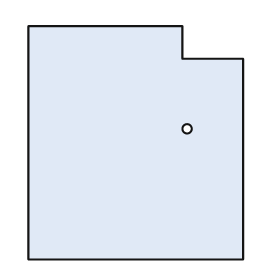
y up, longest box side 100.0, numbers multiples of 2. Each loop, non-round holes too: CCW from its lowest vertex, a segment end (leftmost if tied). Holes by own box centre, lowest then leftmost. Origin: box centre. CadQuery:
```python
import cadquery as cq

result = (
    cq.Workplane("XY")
    .moveTo(-46.0, -50.0)
    .lineTo(46.0, -50.0)
    .lineTo(46.0, 36.0)
    .lineTo(20.0, 36.0)
    .lineTo(20.0, 50.0)
    .lineTo(-46.0, 50.0)
    .close()
    .moveTo(22.0, 6.0)
    .circle(2.0)
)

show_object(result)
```